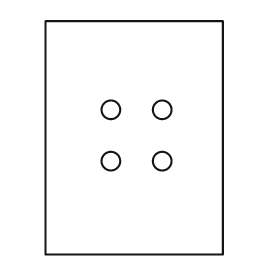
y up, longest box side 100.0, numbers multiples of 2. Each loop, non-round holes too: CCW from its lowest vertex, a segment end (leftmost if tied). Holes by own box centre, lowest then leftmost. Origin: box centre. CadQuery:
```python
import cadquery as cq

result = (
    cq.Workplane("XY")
    .moveTo(-38.0, -50.0)
    .lineTo(38.0, -50.0)
    .lineTo(38.0, 50.0)
    .lineTo(-38.0, 50.0)
    .close()
    .moveTo(-10.0, -10.0)
    .circle(4.0)
    .moveTo(12.0, -10.0)
    .circle(4.0)
    .moveTo(-10.0, 12.0)
    .circle(4.0)
    .moveTo(12.0, 12.0)
    .circle(4.0)
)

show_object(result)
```